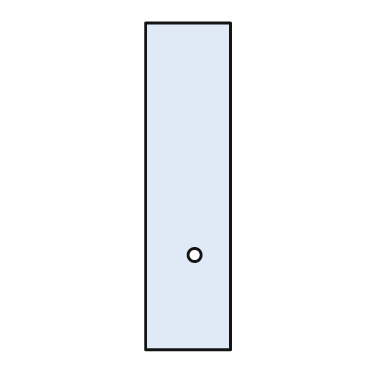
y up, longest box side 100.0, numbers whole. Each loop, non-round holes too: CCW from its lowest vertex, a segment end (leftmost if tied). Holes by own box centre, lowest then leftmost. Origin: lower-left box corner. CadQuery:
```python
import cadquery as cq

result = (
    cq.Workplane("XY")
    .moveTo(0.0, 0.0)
    .lineTo(26.0, 0.0)
    .lineTo(26.0, 100.0)
    .lineTo(0.0, 100.0)
    .close()
    .moveTo(15.0, 29.0)
    .circle(2.0)
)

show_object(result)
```